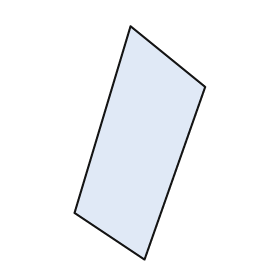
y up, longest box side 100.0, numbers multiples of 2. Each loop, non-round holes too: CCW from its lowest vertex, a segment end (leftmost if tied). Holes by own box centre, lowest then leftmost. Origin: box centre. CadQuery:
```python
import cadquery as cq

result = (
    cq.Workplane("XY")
    .moveTo(2.0, -50.0)
    .lineTo(28.0, 24.0)
    .lineTo(-4.0, 50.0)
    .lineTo(-28.0, -30.0)
    .close()
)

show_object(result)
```